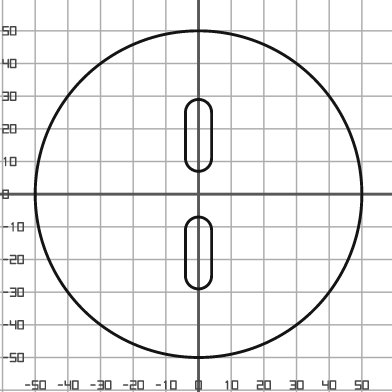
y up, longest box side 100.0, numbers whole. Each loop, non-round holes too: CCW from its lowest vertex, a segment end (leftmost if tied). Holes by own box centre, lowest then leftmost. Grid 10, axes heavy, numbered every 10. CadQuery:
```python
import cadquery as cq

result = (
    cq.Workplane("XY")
    .moveTo(0.0, 0.0)
    .circle(50.0)
    .moveTo(-4.0, -25.0)
    .threePointArc((0.0, -29.0), (4.0, -25.0))
    .lineTo(4.0, -11.0)
    .threePointArc((0.0, -7.0), (-4.0, -11.0))
    .close()
    .moveTo(-4.0, 11.0)
    .threePointArc((0.0, 7.0), (4.0, 11.0))
    .lineTo(4.0, 25.0)
    .threePointArc((0.0, 29.0), (-4.0, 25.0))
    .close()
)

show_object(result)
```